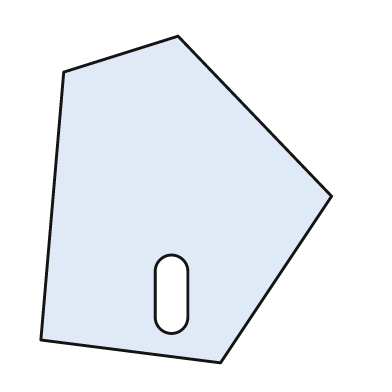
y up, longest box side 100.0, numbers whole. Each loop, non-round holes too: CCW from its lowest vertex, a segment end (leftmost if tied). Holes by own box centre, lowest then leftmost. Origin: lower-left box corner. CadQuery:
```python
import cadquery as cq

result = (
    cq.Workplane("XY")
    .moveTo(55.0, 0.0)
    .lineTo(89.0, 51.0)
    .lineTo(42.0, 100.0)
    .lineTo(7.0, 89.0)
    .lineTo(0.0, 7.0)
    .close()
    .moveTo(35.0, 14.0)
    .threePointArc((40.0, 9.0), (45.0, 14.0))
    .lineTo(45.0, 28.0)
    .threePointArc((40.0, 33.0), (35.0, 28.0))
    .close()
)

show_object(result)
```